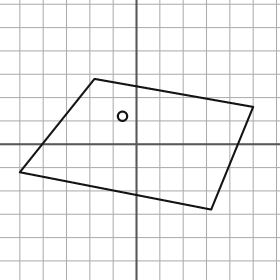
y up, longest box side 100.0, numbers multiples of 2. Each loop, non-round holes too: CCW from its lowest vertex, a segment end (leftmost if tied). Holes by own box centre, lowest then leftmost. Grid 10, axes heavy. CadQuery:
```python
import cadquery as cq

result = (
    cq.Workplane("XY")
    .moveTo(32.0, -28.0)
    .lineTo(50.0, 16.0)
    .lineTo(-18.0, 28.0)
    .lineTo(-50.0, -12.0)
    .close()
    .moveTo(-6.0, 12.0)
    .circle(2.0)
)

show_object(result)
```